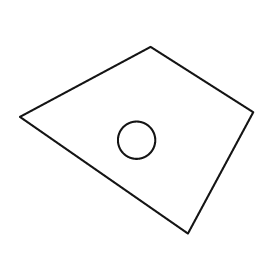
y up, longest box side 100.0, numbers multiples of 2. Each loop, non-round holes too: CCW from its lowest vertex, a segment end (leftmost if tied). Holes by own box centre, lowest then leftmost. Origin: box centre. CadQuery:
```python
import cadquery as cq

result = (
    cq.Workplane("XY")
    .moveTo(22.0, -40.0)
    .lineTo(50.0, 12.0)
    .lineTo(6.0, 40.0)
    .lineTo(-50.0, 10.0)
    .close()
    .moveTo(0.0, 0.0)
    .circle(8.0)
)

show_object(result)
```